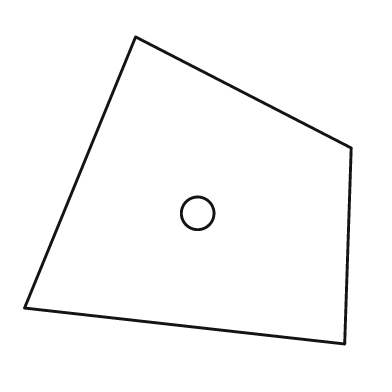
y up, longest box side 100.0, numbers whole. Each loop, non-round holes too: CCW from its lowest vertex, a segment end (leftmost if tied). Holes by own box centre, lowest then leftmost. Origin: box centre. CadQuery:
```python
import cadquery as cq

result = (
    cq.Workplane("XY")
    .moveTo(48.0, -47.0)
    .lineTo(50.0, 13.0)
    .lineTo(-16.0, 47.0)
    .lineTo(-50.0, -36.0)
    .close()
    .moveTo(3.0, -7.0)
    .circle(5.0)
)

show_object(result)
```